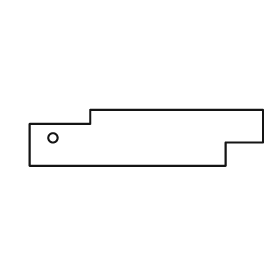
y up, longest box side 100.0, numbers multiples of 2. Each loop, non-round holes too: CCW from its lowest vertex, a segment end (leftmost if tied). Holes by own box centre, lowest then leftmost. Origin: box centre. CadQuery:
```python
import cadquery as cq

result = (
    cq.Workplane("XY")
    .moveTo(-50.0, -12.0)
    .lineTo(34.0, -12.0)
    .lineTo(34.0, -2.0)
    .lineTo(50.0, -2.0)
    .lineTo(50.0, 12.0)
    .lineTo(-24.0, 12.0)
    .lineTo(-24.0, 6.0)
    .lineTo(-50.0, 6.0)
    .close()
    .moveTo(-40.0, 0.0)
    .circle(2.0)
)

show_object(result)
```